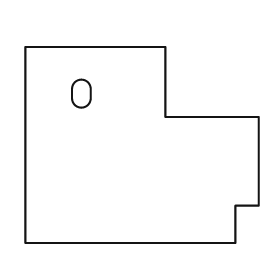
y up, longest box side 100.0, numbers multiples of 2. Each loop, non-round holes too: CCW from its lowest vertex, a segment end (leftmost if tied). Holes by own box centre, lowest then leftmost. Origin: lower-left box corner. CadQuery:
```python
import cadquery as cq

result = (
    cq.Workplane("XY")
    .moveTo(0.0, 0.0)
    .lineTo(90.0, 0.0)
    .lineTo(90.0, 16.0)
    .lineTo(100.0, 16.0)
    .lineTo(100.0, 54.0)
    .lineTo(60.0, 54.0)
    .lineTo(60.0, 84.0)
    .lineTo(0.0, 84.0)
    .close()
    .moveTo(20.0, 62.0)
    .threePointArc((24.0, 58.0), (28.0, 62.0))
    .lineTo(28.0, 66.0)
    .threePointArc((24.0, 70.0), (20.0, 66.0))
    .close()
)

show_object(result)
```